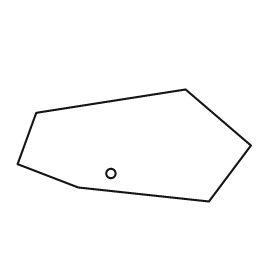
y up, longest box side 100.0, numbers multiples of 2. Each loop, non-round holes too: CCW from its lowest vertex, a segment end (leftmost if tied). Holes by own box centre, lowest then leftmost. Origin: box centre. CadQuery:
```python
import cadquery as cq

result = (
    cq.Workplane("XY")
    .moveTo(32.0, -24.0)
    .lineTo(50.0, 0.0)
    .lineTo(22.0, 24.0)
    .lineTo(-42.0, 14.0)
    .lineTo(-50.0, -8.0)
    .lineTo(-24.0, -18.0)
    .close()
    .moveTo(-10.0, -12.0)
    .circle(2.0)
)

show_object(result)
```